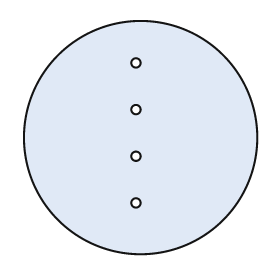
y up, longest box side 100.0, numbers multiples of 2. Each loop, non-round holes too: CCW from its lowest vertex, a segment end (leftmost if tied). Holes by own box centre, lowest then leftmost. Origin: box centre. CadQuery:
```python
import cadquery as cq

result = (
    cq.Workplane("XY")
    .moveTo(0.0, 0.0)
    .circle(50.0)
    .moveTo(-2.0, -28.0)
    .circle(2.0)
    .moveTo(-2.0, -8.0)
    .circle(2.0)
    .moveTo(-2.0, 12.0)
    .circle(2.0)
    .moveTo(-2.0, 32.0)
    .circle(2.0)
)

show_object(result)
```